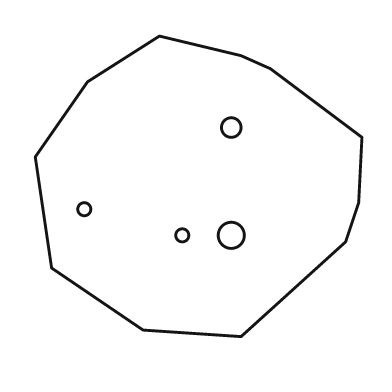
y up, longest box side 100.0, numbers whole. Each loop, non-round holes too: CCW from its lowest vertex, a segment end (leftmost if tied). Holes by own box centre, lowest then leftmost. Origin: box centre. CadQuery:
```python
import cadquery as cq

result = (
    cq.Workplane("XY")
    .moveTo(13.0, -46.0)
    .lineTo(45.0, -17.0)
    .lineTo(49.0, -5.0)
    .lineTo(50.0, 15.0)
    .lineTo(22.0, 36.0)
    .lineTo(13.0, 40.0)
    .lineTo(-12.0, 46.0)
    .lineTo(-34.0, 32.0)
    .lineTo(-50.0, 9.0)
    .lineTo(-45.0, -25.0)
    .lineTo(-17.0, -44.0)
    .close()
    .moveTo(-5.0, -15.0)
    .circle(2.0)
    .moveTo(10.0, -15.0)
    .circle(4.0)
    .moveTo(-35.0, -7.0)
    .circle(2.0)
    .moveTo(10.0, 18.0)
    .circle(3.0)
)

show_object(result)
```